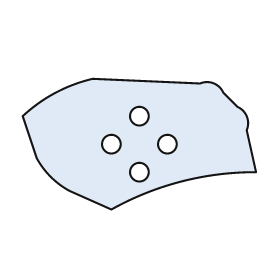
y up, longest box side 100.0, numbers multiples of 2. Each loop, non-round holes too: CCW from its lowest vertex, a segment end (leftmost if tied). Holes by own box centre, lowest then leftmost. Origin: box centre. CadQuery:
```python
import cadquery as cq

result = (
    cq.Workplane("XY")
    .moveTo(-12.0, -28.0)
    .threePointArc((18.0, -16.0), (50.0, -12.0))
    .lineTo(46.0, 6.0)
    .threePointArc((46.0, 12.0), (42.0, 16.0))
    .lineTo(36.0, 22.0)
    .threePointArc((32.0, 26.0), (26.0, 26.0))
    .lineTo(-20.0, 28.0)
    .threePointArc((-36.0, 22.0), (-50.0, 12.0))
    .lineTo(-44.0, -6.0)
    .threePointArc((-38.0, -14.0), (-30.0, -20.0))
    .close()
    .moveTo(0.0, -12.0)
    .circle(4.0)
    .moveTo(-12.0, 0.0)
    .circle(4.0)
    .moveTo(12.0, 0.0)
    .circle(4.0)
    .moveTo(0.0, 12.0)
    .circle(4.0)
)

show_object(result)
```